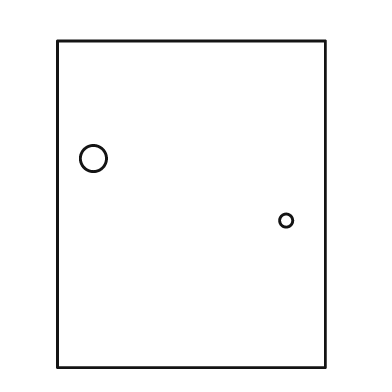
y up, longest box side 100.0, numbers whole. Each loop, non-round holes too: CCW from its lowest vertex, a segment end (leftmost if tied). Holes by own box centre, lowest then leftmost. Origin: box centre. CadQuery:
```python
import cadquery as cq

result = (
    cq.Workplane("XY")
    .moveTo(-41.0, -50.0)
    .lineTo(41.0, -50.0)
    .lineTo(41.0, 50.0)
    .lineTo(-41.0, 50.0)
    .close()
    .moveTo(29.0, -5.0)
    .circle(2.0)
    .moveTo(-30.0, 14.0)
    .circle(4.0)
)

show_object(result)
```